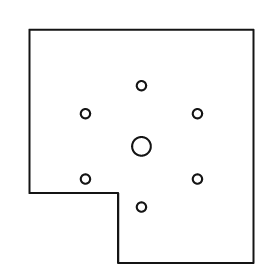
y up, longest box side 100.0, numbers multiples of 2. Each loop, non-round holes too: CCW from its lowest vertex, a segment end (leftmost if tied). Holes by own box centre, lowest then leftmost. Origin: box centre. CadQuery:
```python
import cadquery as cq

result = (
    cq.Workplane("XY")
    .moveTo(-10.0, -50.0)
    .lineTo(48.0, -50.0)
    .lineTo(48.0, 50.0)
    .lineTo(-48.0, 50.0)
    .lineTo(-48.0, -20.0)
    .lineTo(-10.0, -20.0)
    .close()
    .moveTo(0.0, -26.0)
    .circle(2.0)
    .moveTo(-24.0, -14.0)
    .circle(2.0)
    .moveTo(24.0, -14.0)
    .circle(2.0)
    .moveTo(0.0, 0.0)
    .circle(4.0)
    .moveTo(-24.0, 14.0)
    .circle(2.0)
    .moveTo(24.0, 14.0)
    .circle(2.0)
    .moveTo(0.0, 26.0)
    .circle(2.0)
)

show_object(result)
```